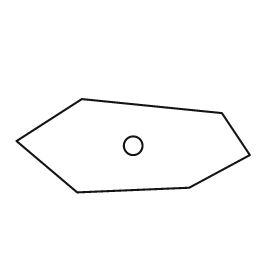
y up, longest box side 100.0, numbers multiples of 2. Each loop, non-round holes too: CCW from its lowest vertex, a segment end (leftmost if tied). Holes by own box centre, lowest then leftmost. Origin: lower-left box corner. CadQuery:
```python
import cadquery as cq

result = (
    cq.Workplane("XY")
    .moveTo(26.0, 0.0)
    .lineTo(74.0, 2.0)
    .lineTo(100.0, 16.0)
    .lineTo(88.0, 34.0)
    .lineTo(28.0, 40.0)
    .lineTo(0.0, 22.0)
    .close()
    .moveTo(50.0, 20.0)
    .circle(4.0)
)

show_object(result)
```